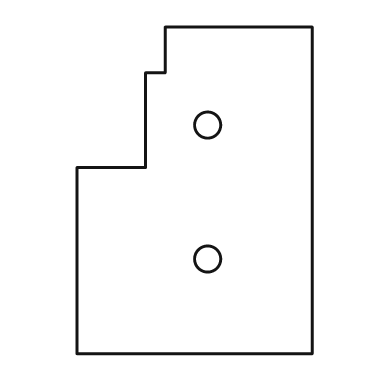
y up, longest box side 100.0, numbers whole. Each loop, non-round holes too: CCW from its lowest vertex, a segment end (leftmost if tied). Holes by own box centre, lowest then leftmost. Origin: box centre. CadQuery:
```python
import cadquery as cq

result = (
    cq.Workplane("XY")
    .moveTo(-36.0, -50.0)
    .lineTo(36.0, -50.0)
    .lineTo(36.0, 50.0)
    .lineTo(-9.0, 50.0)
    .lineTo(-9.0, 36.0)
    .lineTo(-15.0, 36.0)
    .lineTo(-15.0, 7.0)
    .lineTo(-36.0, 7.0)
    .close()
    .moveTo(4.0, -21.0)
    .circle(4.0)
    .moveTo(4.0, 20.0)
    .circle(4.0)
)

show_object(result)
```